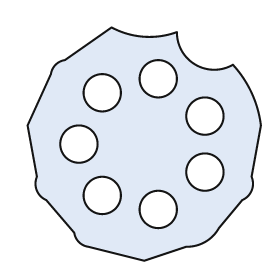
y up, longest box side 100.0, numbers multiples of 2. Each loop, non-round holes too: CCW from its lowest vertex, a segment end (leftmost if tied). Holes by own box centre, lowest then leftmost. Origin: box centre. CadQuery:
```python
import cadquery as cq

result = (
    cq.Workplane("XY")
    .moveTo(0.0, -50.0)
    .lineTo(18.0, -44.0)
    .threePointArc((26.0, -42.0), (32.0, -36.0))
    .lineTo(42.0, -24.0)
    .threePointArc((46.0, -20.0), (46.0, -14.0))
    .lineTo(50.0, 8.0)
    .threePointArc((46.0, 22.0), (38.0, 34.0))
    .threePointArc((22.0, 34.0), (14.0, 48.0))
    .threePointArc((0.0, 46.0), (-14.0, 50.0))
    .lineTo(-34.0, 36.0)
    .threePointArc((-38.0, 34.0), (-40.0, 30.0))
    .lineTo(-50.0, 8.0)
    .lineTo(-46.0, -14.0)
    .threePointArc((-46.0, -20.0), (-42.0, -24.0))
    .lineTo(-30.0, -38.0)
    .threePointArc((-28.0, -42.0), (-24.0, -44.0))
    .close()
    .moveTo(6.0, -28.0)
    .circle(8.0)
    .moveTo(-18.0, -22.0)
    .circle(8.0)
    .moveTo(26.0, -12.0)
    .circle(8.0)
    .moveTo(-28.0, 0.0)
    .circle(8.0)
    .moveTo(26.0, 12.0)
    .circle(8.0)
    .moveTo(-18.0, 22.0)
    .circle(8.0)
    .moveTo(6.0, 28.0)
    .circle(8.0)
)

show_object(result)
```